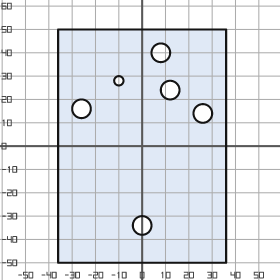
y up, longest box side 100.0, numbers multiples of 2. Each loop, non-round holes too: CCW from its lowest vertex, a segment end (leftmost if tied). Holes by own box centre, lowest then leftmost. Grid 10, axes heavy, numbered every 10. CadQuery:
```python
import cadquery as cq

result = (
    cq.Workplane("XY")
    .moveTo(-36.0, -50.0)
    .lineTo(36.0, -50.0)
    .lineTo(36.0, 50.0)
    .lineTo(-36.0, 50.0)
    .close()
    .moveTo(0.0, -34.0)
    .circle(4.0)
    .moveTo(26.0, 14.0)
    .circle(4.0)
    .moveTo(-26.0, 16.0)
    .circle(4.0)
    .moveTo(12.0, 24.0)
    .circle(4.0)
    .moveTo(-10.0, 28.0)
    .circle(2.0)
    .moveTo(8.0, 40.0)
    .circle(4.0)
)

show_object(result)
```